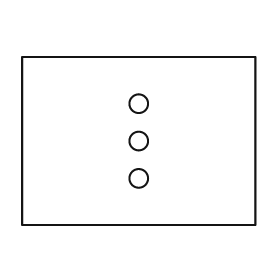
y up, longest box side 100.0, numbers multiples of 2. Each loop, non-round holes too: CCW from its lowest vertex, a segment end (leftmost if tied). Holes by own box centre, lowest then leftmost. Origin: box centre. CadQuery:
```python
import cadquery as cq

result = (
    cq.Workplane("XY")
    .moveTo(-50.0, -36.0)
    .lineTo(50.0, -36.0)
    .lineTo(50.0, 36.0)
    .lineTo(-50.0, 36.0)
    .close()
    .moveTo(0.0, -16.0)
    .circle(4.0)
    .moveTo(0.0, 0.0)
    .circle(4.0)
    .moveTo(0.0, 16.0)
    .circle(4.0)
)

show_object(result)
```